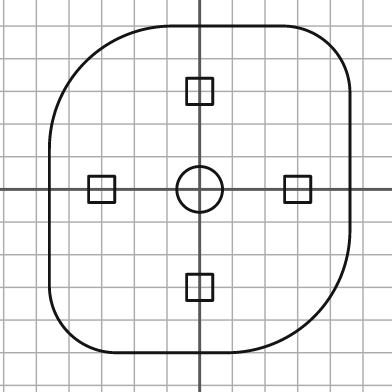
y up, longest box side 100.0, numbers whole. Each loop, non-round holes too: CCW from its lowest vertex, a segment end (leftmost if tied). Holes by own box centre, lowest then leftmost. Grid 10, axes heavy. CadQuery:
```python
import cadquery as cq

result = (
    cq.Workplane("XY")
    .moveTo(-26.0, -50.0)
    .lineTo(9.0, -50.0)
    .threePointArc((35.0, -39.0), (46.0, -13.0))
    .lineTo(46.0, 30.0)
    .threePointArc((40.0, 44.0), (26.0, 50.0))
    .lineTo(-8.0, 50.0)
    .threePointArc((-35.0, 39.0), (-46.0, 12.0))
    .lineTo(-46.0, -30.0)
    .threePointArc((-40.0, -44.0), (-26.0, -50.0))
    .close()
    .moveTo(-4.0, -34.0)
    .lineTo(4.0, -34.0)
    .lineTo(4.0, -26.0)
    .lineTo(-4.0, -26.0)
    .close()
    .moveTo(-34.0, -4.0)
    .lineTo(-26.0, -4.0)
    .lineTo(-26.0, 4.0)
    .lineTo(-34.0, 4.0)
    .close()
    .moveTo(0.0, 0.0)
    .circle(7.0)
    .moveTo(26.0, -4.0)
    .lineTo(34.0, -4.0)
    .lineTo(34.0, 4.0)
    .lineTo(26.0, 4.0)
    .close()
    .moveTo(-4.0, 26.0)
    .lineTo(4.0, 26.0)
    .lineTo(4.0, 34.0)
    .lineTo(-4.0, 34.0)
    .close()
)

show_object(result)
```